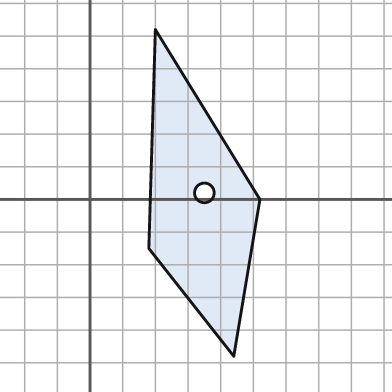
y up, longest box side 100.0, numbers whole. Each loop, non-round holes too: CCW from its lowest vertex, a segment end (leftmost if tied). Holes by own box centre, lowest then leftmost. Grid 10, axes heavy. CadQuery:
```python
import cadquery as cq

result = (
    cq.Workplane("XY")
    .moveTo(44.0, -48.0)
    .lineTo(52.0, 0.0)
    .lineTo(20.0, 52.0)
    .lineTo(18.0, -15.0)
    .close()
    .moveTo(35.0, 2.0)
    .circle(3.0)
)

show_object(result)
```